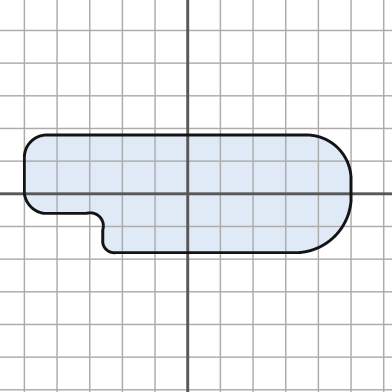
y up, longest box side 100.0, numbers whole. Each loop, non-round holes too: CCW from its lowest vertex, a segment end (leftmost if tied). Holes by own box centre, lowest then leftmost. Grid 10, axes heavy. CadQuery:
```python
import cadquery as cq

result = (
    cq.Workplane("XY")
    .moveTo(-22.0, -18.0)
    .lineTo(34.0, -18.0)
    .threePointArc((45.0, -13.0), (50.0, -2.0))
    .lineTo(50.0, 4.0)
    .threePointArc((46.0, 14.0), (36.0, 18.0))
    .lineTo(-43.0, 18.0)
    .threePointArc((-48.0, 16.0), (-50.0, 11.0))
    .lineTo(-50.0, 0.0)
    .threePointArc((-48.0, -4.0), (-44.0, -6.0))
    .lineTo(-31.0, -6.0)
    .threePointArc((-27.0, -7.0), (-26.0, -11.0))
    .lineTo(-26.0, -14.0)
    .threePointArc((-25.0, -17.0), (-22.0, -18.0))
    .close()
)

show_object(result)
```